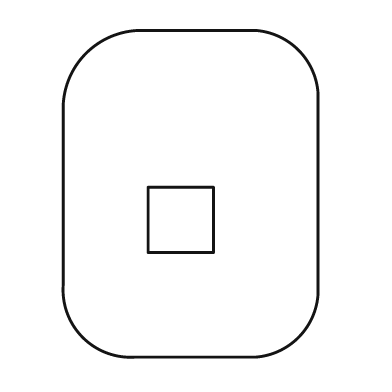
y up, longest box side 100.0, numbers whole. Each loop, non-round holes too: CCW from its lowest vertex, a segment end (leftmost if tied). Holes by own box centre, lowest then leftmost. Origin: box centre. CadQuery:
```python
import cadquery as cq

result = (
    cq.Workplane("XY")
    .moveTo(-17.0, -50.0)
    .lineTo(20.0, -50.0)
    .threePointArc((33.0, -44.0), (39.0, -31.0))
    .lineTo(39.0, 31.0)
    .threePointArc((33.0, 44.0), (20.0, 50.0))
    .lineTo(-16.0, 50.0)
    .threePointArc((-32.0, 43.0), (-39.0, 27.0))
    .lineTo(-39.0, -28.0)
    .threePointArc((-33.0, -44.0), (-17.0, -50.0))
    .close()
    .moveTo(-13.0, -18.0)
    .lineTo(7.0, -18.0)
    .lineTo(7.0, 2.0)
    .lineTo(-13.0, 2.0)
    .close()
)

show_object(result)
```